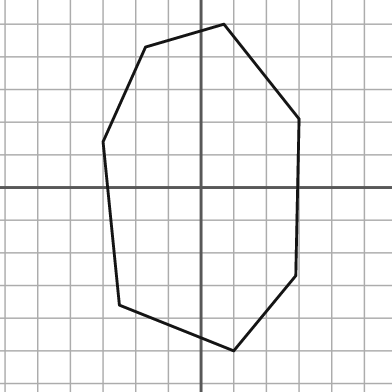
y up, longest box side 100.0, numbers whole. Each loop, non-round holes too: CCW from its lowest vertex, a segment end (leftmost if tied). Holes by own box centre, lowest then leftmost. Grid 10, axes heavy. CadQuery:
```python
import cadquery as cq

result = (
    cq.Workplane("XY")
    .moveTo(10.0, -50.0)
    .lineTo(29.0, -27.0)
    .lineTo(30.0, 21.0)
    .lineTo(7.0, 50.0)
    .lineTo(-17.0, 43.0)
    .lineTo(-30.0, 14.0)
    .lineTo(-25.0, -36.0)
    .close()
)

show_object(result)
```